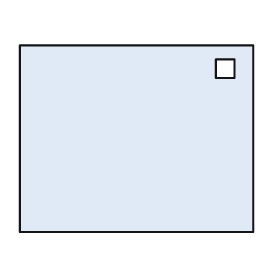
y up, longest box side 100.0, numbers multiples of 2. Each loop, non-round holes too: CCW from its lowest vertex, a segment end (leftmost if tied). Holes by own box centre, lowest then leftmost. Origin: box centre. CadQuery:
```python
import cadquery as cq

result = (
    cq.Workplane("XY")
    .moveTo(-50.0, -40.0)
    .lineTo(50.0, -40.0)
    .lineTo(50.0, 40.0)
    .lineTo(-50.0, 40.0)
    .close()
    .moveTo(34.0, 26.0)
    .lineTo(42.0, 26.0)
    .lineTo(42.0, 34.0)
    .lineTo(34.0, 34.0)
    .close()
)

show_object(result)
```